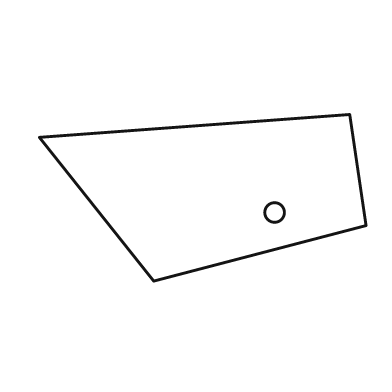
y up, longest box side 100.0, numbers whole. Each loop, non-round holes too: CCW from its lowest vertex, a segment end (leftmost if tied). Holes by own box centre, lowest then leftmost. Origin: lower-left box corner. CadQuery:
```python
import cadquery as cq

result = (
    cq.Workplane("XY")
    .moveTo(35.0, 0.0)
    .lineTo(100.0, 17.0)
    .lineTo(95.0, 51.0)
    .lineTo(0.0, 44.0)
    .close()
    .moveTo(72.0, 21.0)
    .circle(3.0)
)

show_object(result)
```